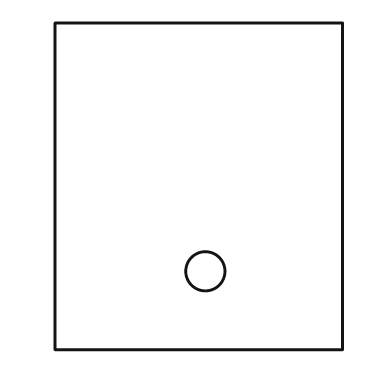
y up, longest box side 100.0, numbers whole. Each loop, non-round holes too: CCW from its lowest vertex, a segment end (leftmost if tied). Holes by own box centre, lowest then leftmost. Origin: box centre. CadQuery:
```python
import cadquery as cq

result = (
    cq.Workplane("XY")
    .moveTo(-44.0, -50.0)
    .lineTo(44.0, -50.0)
    .lineTo(44.0, 50.0)
    .lineTo(-44.0, 50.0)
    .close()
    .moveTo(2.0, -26.0)
    .circle(6.0)
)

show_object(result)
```